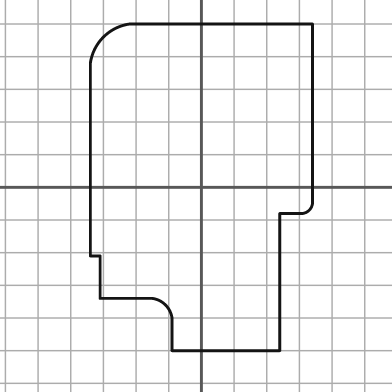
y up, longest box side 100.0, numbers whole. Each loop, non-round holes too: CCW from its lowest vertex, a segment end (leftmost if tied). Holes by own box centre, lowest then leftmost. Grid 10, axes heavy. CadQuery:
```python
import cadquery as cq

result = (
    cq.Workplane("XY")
    .moveTo(-9.0, -50.0)
    .lineTo(24.0, -50.0)
    .lineTo(24.0, -8.0)
    .lineTo(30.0, -8.0)
    .threePointArc((33.0, -7.0), (34.0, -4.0))
    .lineTo(34.0, 50.0)
    .lineTo(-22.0, 50.0)
    .threePointArc((-30.0, 46.0), (-34.0, 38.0))
    .lineTo(-34.0, -21.0)
    .lineTo(-31.0, -21.0)
    .lineTo(-31.0, -34.0)
    .lineTo(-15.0, -34.0)
    .threePointArc((-11.0, -36.0), (-9.0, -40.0))
    .close()
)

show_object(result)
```